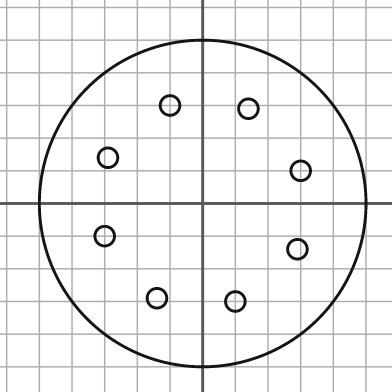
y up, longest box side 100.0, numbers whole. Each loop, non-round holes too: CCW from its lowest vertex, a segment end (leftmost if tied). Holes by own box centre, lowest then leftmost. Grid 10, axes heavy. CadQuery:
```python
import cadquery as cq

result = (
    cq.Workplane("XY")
    .moveTo(0.0, 0.0)
    .circle(50.0)
    .moveTo(10.0, -30.0)
    .circle(3.0)
    .moveTo(-14.0, -29.0)
    .circle(3.0)
    .moveTo(29.0, -14.0)
    .circle(3.0)
    .moveTo(-30.0, -10.0)
    .circle(3.0)
    .moveTo(30.0, 10.0)
    .circle(3.0)
    .moveTo(-29.0, 14.0)
    .circle(3.0)
    .moveTo(14.0, 29.0)
    .circle(3.0)
    .moveTo(-10.0, 30.0)
    .circle(3.0)
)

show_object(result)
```